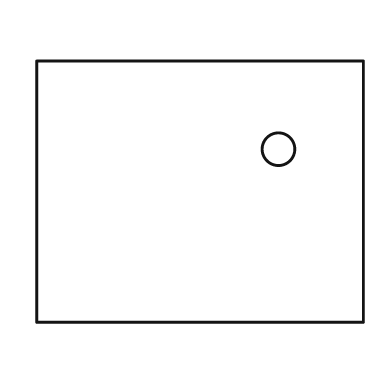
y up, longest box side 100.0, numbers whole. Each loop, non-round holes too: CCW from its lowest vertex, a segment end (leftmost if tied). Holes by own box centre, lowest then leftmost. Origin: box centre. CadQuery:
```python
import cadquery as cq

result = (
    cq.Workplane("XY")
    .moveTo(-50.0, -40.0)
    .lineTo(50.0, -40.0)
    .lineTo(50.0, 40.0)
    .lineTo(-50.0, 40.0)
    .close()
    .moveTo(24.0, 13.0)
    .circle(5.0)
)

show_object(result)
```